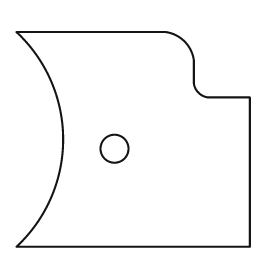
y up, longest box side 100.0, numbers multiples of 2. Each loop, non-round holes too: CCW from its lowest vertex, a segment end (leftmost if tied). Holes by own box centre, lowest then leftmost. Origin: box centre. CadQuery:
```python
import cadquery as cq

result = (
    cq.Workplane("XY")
    .moveTo(-50.0, -46.0)
    .lineTo(50.0, -46.0)
    .lineTo(50.0, 18.0)
    .lineTo(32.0, 18.0)
    .threePointArc((28.0, 20.0), (26.0, 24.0))
    .lineTo(26.0, 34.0)
    .threePointArc((22.0, 42.0), (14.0, 46.0))
    .lineTo(-50.0, 46.0)
    .threePointArc((-30.0, 0.0), (-50.0, -46.0))
    .close()
    .moveTo(-8.0, -4.0)
    .circle(6.0)
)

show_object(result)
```